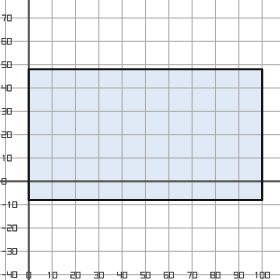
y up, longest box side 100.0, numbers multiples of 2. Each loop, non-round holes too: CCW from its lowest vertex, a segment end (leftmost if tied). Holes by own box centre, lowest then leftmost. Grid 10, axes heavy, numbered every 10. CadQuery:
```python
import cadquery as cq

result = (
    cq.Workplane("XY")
    .moveTo(0.0, -8.0)
    .lineTo(100.0, -8.0)
    .lineTo(100.0, 48.0)
    .lineTo(0.0, 48.0)
    .close()
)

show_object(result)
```